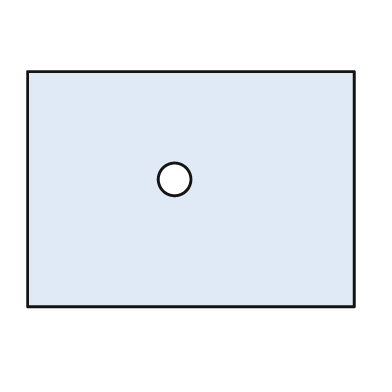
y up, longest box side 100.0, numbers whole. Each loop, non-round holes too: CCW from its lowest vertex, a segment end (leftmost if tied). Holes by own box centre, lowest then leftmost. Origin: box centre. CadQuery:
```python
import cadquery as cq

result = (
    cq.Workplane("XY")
    .moveTo(-50.0, -36.0)
    .lineTo(50.0, -36.0)
    .lineTo(50.0, 36.0)
    .lineTo(-50.0, 36.0)
    .close()
    .moveTo(-5.0, 3.0)
    .circle(5.0)
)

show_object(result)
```